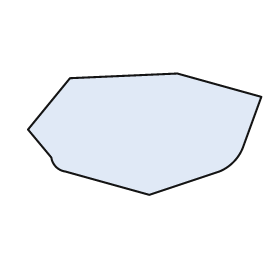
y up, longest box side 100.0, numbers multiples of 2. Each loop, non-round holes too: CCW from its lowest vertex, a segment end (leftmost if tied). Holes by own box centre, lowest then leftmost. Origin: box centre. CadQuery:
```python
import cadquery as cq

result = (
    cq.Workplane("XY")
    .moveTo(2.0, -26.0)
    .lineTo(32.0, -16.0)
    .threePointArc((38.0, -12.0), (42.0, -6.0))
    .lineTo(50.0, 16.0)
    .lineTo(14.0, 26.0)
    .lineTo(-32.0, 24.0)
    .lineTo(-50.0, 2.0)
    .lineTo(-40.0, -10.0)
    .threePointArc((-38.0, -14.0), (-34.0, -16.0))
    .close()
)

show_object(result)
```